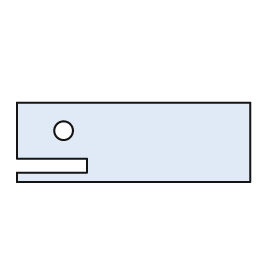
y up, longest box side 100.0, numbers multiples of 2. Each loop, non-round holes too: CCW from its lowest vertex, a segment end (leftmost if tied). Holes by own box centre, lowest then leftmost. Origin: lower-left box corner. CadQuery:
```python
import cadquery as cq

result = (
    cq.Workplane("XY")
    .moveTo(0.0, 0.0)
    .lineTo(100.0, 0.0)
    .lineTo(100.0, 34.0)
    .lineTo(0.0, 34.0)
    .lineTo(0.0, 10.0)
    .lineTo(30.0, 10.0)
    .lineTo(30.0, 4.0)
    .lineTo(0.0, 4.0)
    .close()
    .moveTo(20.0, 22.0)
    .circle(4.0)
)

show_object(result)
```